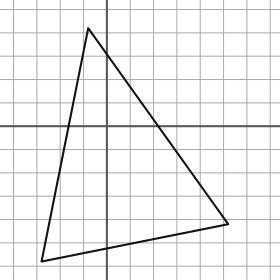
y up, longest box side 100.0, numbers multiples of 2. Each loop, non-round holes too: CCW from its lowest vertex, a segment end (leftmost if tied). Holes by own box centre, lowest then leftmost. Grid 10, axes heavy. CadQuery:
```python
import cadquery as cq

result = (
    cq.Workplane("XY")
    .moveTo(-28.0, -58.0)
    .lineTo(52.0, -42.0)
    .lineTo(-8.0, 42.0)
    .close()
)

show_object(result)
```